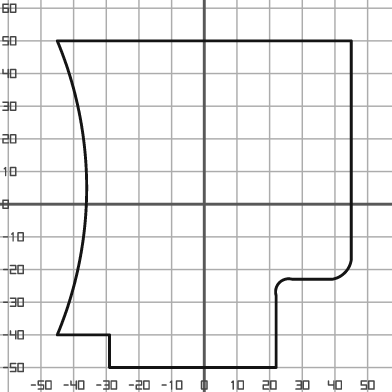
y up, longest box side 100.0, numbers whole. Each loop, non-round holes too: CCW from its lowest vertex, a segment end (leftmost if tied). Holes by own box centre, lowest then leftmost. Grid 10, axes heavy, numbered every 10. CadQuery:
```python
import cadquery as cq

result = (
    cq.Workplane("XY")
    .moveTo(-29.0, -50.0)
    .lineTo(22.0, -50.0)
    .lineTo(22.0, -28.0)
    .threePointArc((23.0, -24.0), (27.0, -23.0))
    .lineTo(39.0, -23.0)
    .threePointArc((43.0, -21.0), (45.0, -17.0))
    .lineTo(45.0, 50.0)
    .lineTo(-45.0, 50.0)
    .threePointArc((-36.0, 5.0), (-45.0, -40.0))
    .lineTo(-29.0, -40.0)
    .close()
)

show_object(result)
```